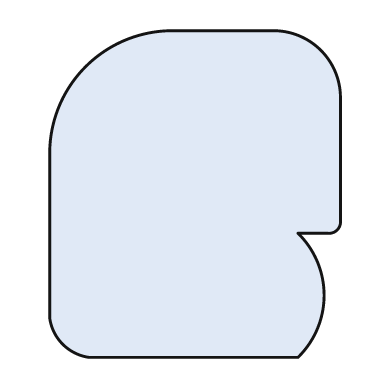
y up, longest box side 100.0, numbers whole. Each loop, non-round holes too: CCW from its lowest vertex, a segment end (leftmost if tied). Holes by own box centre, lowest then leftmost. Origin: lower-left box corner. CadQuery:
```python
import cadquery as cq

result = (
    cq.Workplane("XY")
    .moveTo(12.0, 0.0)
    .lineTo(76.0, 0.0)
    .threePointArc((84.0, 19.0), (76.0, 38.0))
    .lineTo(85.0, 38.0)
    .threePointArc((88.0, 39.0), (89.0, 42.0))
    .lineTo(89.0, 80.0)
    .threePointArc((83.0, 94.0), (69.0, 100.0))
    .lineTo(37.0, 100.0)
    .threePointArc((11.0, 89.0), (0.0, 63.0))
    .lineTo(0.0, 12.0)
    .threePointArc((4.0, 4.0), (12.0, 0.0))
    .close()
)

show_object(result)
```